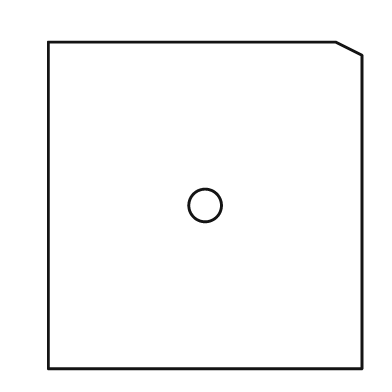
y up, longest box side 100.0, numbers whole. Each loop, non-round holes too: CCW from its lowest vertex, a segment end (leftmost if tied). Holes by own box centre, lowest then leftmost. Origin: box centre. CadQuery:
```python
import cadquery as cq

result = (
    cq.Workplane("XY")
    .moveTo(-48.0, -50.0)
    .lineTo(48.0, -50.0)
    .lineTo(48.0, 46.0)
    .lineTo(40.0, 50.0)
    .lineTo(-48.0, 50.0)
    .close()
    .moveTo(0.0, 0.0)
    .circle(5.0)
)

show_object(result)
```